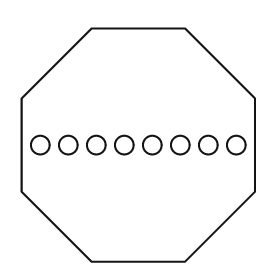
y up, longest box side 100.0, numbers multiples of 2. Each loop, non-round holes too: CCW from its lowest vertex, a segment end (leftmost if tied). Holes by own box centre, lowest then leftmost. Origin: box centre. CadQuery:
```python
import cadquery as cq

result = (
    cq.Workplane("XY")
    .moveTo(-20.0, -50.0)
    .lineTo(20.0, -50.0)
    .lineTo(50.0, -20.0)
    .lineTo(50.0, 20.0)
    .lineTo(20.0, 50.0)
    .lineTo(-20.0, 50.0)
    .lineTo(-50.0, 20.0)
    .lineTo(-50.0, -20.0)
    .close()
    .moveTo(-42.0, 0.0)
    .circle(4.0)
    .moveTo(-30.0, 0.0)
    .circle(4.0)
    .moveTo(-18.0, 0.0)
    .circle(4.0)
    .moveTo(-6.0, 0.0)
    .circle(4.0)
    .moveTo(6.0, 0.0)
    .circle(4.0)
    .moveTo(18.0, 0.0)
    .circle(4.0)
    .moveTo(30.0, 0.0)
    .circle(4.0)
    .moveTo(42.0, 0.0)
    .circle(4.0)
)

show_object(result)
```